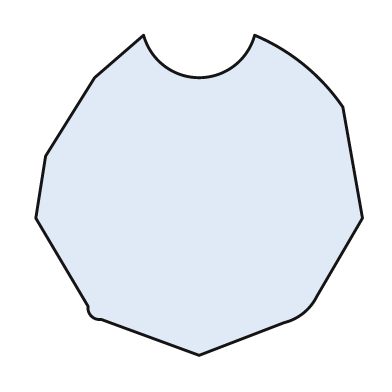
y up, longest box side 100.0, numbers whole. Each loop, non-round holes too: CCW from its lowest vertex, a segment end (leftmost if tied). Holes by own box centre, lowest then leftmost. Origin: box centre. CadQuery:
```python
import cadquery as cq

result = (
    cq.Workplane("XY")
    .moveTo(0.0, -49.0)
    .lineTo(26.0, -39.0)
    .threePointArc((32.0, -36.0), (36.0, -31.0))
    .lineTo(50.0, -7.0)
    .lineTo(44.0, 27.0)
    .threePointArc((32.0, 40.0), (17.0, 49.0))
    .threePointArc((0.0, 36.0), (-17.0, 49.0))
    .lineTo(-32.0, 36.0)
    .lineTo(-47.0, 12.0)
    .lineTo(-50.0, -7.0)
    .lineTo(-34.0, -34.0)
    .threePointArc((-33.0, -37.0), (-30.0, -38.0))
    .close()
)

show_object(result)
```